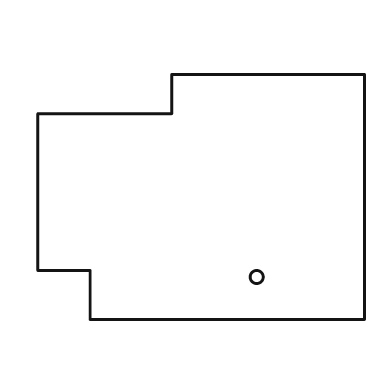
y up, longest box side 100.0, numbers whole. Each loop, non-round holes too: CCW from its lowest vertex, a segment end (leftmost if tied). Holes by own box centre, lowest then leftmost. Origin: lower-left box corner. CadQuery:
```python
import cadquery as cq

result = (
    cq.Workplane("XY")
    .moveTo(16.0, 0.0)
    .lineTo(100.0, 0.0)
    .lineTo(100.0, 75.0)
    .lineTo(41.0, 75.0)
    .lineTo(41.0, 63.0)
    .lineTo(0.0, 63.0)
    .lineTo(0.0, 15.0)
    .lineTo(16.0, 15.0)
    .close()
    .moveTo(67.0, 13.0)
    .circle(2.0)
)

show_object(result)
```